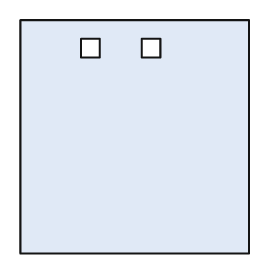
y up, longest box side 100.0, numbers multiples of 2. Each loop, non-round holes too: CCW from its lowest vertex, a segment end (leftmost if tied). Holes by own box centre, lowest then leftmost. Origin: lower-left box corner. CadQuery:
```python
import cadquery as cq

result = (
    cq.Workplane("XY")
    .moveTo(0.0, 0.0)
    .lineTo(98.0, 0.0)
    .lineTo(98.0, 100.0)
    .lineTo(0.0, 100.0)
    .close()
    .moveTo(26.0, 84.0)
    .lineTo(34.0, 84.0)
    .lineTo(34.0, 92.0)
    .lineTo(26.0, 92.0)
    .close()
    .moveTo(52.0, 84.0)
    .lineTo(60.0, 84.0)
    .lineTo(60.0, 92.0)
    .lineTo(52.0, 92.0)
    .close()
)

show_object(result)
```